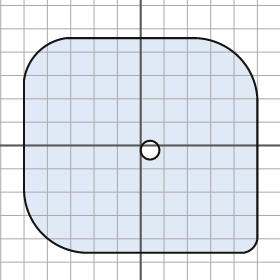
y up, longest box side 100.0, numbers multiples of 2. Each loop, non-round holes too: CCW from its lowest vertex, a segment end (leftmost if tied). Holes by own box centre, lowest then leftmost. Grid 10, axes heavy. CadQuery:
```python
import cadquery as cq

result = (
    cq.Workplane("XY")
    .moveTo(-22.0, -46.0)
    .lineTo(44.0, -46.0)
    .threePointArc((48.0, -44.0), (50.0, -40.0))
    .lineTo(50.0, 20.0)
    .threePointArc((42.0, 38.0), (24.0, 46.0))
    .lineTo(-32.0, 46.0)
    .threePointArc((-44.0, 40.0), (-50.0, 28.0))
    .lineTo(-50.0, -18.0)
    .threePointArc((-42.0, -38.0), (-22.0, -46.0))
    .close()
    .moveTo(4.0, -2.0)
    .circle(4.0)
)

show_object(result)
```